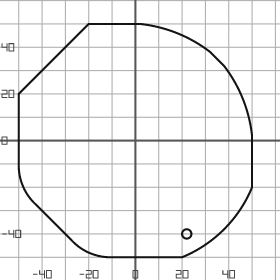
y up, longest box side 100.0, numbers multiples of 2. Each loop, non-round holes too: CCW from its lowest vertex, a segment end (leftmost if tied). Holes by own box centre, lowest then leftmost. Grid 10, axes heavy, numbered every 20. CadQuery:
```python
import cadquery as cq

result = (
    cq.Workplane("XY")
    .moveTo(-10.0, -50.0)
    .lineTo(20.0, -50.0)
    .threePointArc((38.0, -38.0), (50.0, -20.0))
    .lineTo(50.0, 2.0)
    .threePointArc((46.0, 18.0), (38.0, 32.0))
    .lineTo(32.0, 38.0)
    .threePointArc((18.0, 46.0), (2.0, 50.0))
    .lineTo(-20.0, 50.0)
    .lineTo(-50.0, 20.0)
    .lineTo(-50.0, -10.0)
    .threePointArc((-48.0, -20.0), (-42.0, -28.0))
    .lineTo(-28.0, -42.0)
    .threePointArc((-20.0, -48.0), (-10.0, -50.0))
    .close()
    .moveTo(22.0, -40.0)
    .circle(2.0)
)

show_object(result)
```